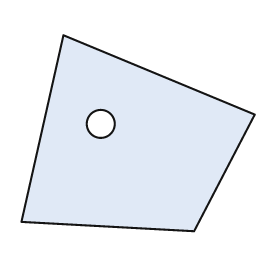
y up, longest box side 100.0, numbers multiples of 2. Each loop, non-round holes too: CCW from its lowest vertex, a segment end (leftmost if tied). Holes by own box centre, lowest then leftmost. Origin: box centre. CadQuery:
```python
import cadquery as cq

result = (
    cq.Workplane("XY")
    .moveTo(24.0, -42.0)
    .lineTo(50.0, 8.0)
    .lineTo(-32.0, 42.0)
    .lineTo(-50.0, -38.0)
    .close()
    .moveTo(-16.0, 4.0)
    .circle(6.0)
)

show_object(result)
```